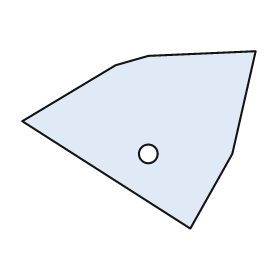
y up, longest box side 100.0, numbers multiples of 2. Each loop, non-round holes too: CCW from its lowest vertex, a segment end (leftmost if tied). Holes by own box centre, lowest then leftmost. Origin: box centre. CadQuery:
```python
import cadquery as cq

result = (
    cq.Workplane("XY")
    .moveTo(22.0, -38.0)
    .lineTo(40.0, -6.0)
    .lineTo(50.0, 38.0)
    .lineTo(4.0, 36.0)
    .lineTo(-10.0, 32.0)
    .lineTo(-50.0, 8.0)
    .close()
    .moveTo(4.0, -6.0)
    .circle(4.0)
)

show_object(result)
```